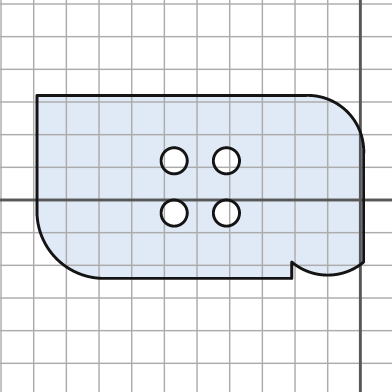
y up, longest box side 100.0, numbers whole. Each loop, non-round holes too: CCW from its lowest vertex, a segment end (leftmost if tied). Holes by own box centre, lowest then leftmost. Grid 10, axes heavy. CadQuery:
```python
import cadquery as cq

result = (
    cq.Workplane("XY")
    .moveTo(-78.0, -24.0)
    .lineTo(-21.0, -24.0)
    .lineTo(-21.0, -19.0)
    .threePointArc((-10.0, -23.0), (1.0, -19.0))
    .lineTo(1.0, 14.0)
    .threePointArc((-4.0, 27.0), (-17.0, 32.0))
    .lineTo(-99.0, 32.0)
    .lineTo(-99.0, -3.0)
    .threePointArc((-93.0, -18.0), (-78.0, -24.0))
    .close()
    .moveTo(-57.0, -4.0)
    .circle(4.0)
    .moveTo(-41.0, -4.0)
    .circle(4.0)
    .moveTo(-57.0, 12.0)
    .circle(4.0)
    .moveTo(-41.0, 12.0)
    .circle(4.0)
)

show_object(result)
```